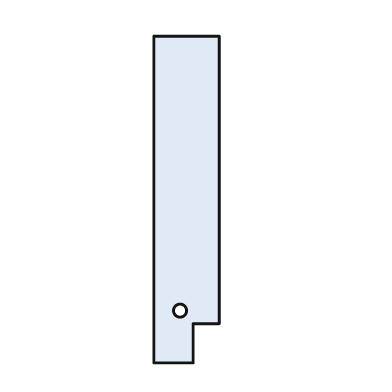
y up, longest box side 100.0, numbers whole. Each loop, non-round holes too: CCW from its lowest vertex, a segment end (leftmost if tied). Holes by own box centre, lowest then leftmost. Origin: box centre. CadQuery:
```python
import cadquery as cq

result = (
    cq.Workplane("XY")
    .moveTo(-10.0, -50.0)
    .lineTo(2.0, -50.0)
    .lineTo(2.0, -38.0)
    .lineTo(10.0, -38.0)
    .lineTo(10.0, 50.0)
    .lineTo(-10.0, 50.0)
    .close()
    .moveTo(-2.0, -34.0)
    .circle(2.0)
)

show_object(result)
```